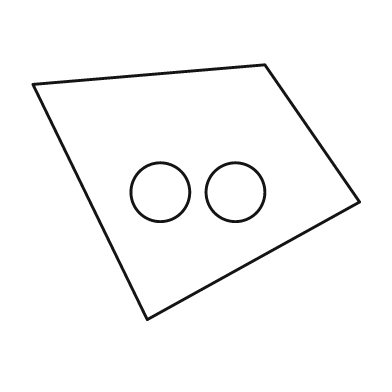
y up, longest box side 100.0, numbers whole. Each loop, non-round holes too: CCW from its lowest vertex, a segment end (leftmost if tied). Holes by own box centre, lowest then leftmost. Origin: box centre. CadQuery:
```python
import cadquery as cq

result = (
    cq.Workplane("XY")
    .moveTo(-15.0, -39.0)
    .lineTo(50.0, -3.0)
    .lineTo(21.0, 39.0)
    .lineTo(-50.0, 33.0)
    .close()
    .moveTo(-11.0, 0.0)
    .circle(9.0)
    .moveTo(12.0, 0.0)
    .circle(9.0)
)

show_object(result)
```